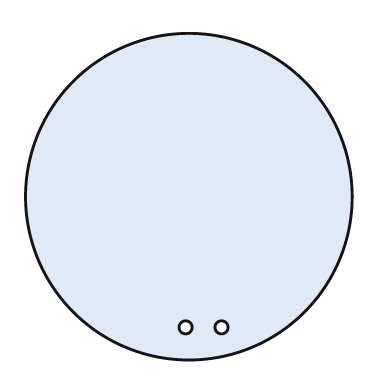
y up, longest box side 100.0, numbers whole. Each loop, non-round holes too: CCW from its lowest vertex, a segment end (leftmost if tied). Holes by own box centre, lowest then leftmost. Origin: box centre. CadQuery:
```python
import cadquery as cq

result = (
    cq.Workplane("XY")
    .moveTo(0.0, 0.0)
    .circle(50.0)
    .moveTo(-1.0, -40.0)
    .circle(2.0)
    .moveTo(10.0, -40.0)
    .circle(2.0)
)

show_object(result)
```